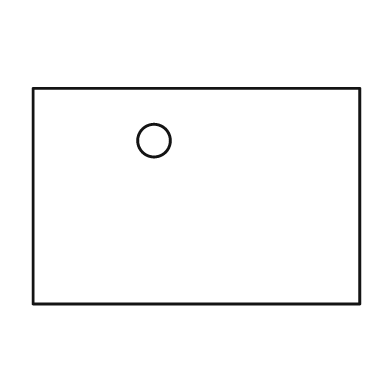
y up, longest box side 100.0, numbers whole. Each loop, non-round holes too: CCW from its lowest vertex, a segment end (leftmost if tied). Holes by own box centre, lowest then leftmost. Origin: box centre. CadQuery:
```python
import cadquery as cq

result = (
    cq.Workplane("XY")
    .moveTo(-50.0, -33.0)
    .lineTo(50.0, -33.0)
    .lineTo(50.0, 33.0)
    .lineTo(-50.0, 33.0)
    .close()
    .moveTo(-13.0, 17.0)
    .circle(5.0)
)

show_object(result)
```